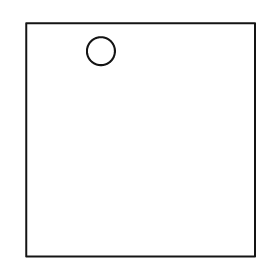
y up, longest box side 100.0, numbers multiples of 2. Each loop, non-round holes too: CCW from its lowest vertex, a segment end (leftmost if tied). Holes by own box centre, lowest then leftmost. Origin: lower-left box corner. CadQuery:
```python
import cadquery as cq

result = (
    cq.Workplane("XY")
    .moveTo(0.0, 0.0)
    .lineTo(98.0, 0.0)
    .lineTo(98.0, 100.0)
    .lineTo(0.0, 100.0)
    .close()
    .moveTo(32.0, 88.0)
    .circle(6.0)
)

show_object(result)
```